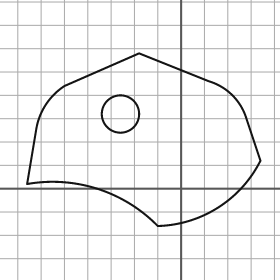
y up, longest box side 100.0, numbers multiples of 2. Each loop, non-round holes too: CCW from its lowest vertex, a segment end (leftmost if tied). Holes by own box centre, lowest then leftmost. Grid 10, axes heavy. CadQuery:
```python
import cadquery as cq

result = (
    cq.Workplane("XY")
    .moveTo(-10.0, -16.0)
    .threePointArc((16.0, -8.0), (34.0, 12.0))
    .lineTo(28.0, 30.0)
    .threePointArc((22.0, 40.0), (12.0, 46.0))
    .lineTo(-18.0, 58.0)
    .lineTo(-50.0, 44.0)
    .threePointArc((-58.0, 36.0), (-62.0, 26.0))
    .lineTo(-66.0, 2.0)
    .threePointArc((-36.0, 0.0), (-10.0, -16.0))
    .close()
    .moveTo(-26.0, 32.0)
    .circle(8.0)
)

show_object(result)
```